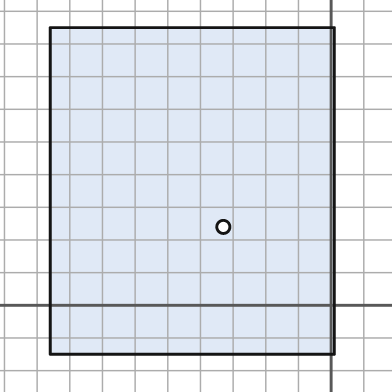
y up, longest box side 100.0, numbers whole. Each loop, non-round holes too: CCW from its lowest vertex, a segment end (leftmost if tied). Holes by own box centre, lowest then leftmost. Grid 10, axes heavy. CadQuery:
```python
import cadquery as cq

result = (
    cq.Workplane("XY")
    .moveTo(-86.0, -15.0)
    .lineTo(1.0, -15.0)
    .lineTo(1.0, 85.0)
    .lineTo(-86.0, 85.0)
    .close()
    .moveTo(-33.0, 24.0)
    .circle(2.0)
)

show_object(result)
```